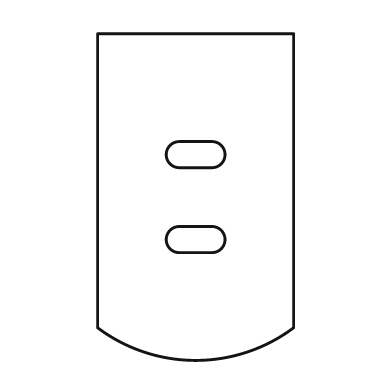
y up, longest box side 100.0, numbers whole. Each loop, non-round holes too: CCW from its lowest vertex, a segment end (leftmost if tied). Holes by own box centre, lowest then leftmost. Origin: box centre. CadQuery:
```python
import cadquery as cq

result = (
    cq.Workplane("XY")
    .moveTo(-30.0, -40.0)
    .threePointArc((0.0, -50.0), (30.0, -40.0))
    .lineTo(30.0, 50.0)
    .lineTo(-30.0, 50.0)
    .close()
    .moveTo(-5.0, -17.0)
    .lineTo(5.0, -17.0)
    .threePointArc((9.0, -13.0), (5.0, -9.0))
    .lineTo(-5.0, -9.0)
    .threePointArc((-9.0, -13.0), (-5.0, -17.0))
    .close()
    .moveTo(-5.0, 9.0)
    .lineTo(5.0, 9.0)
    .threePointArc((9.0, 13.0), (5.0, 17.0))
    .lineTo(-5.0, 17.0)
    .threePointArc((-9.0, 13.0), (-5.0, 9.0))
    .close()
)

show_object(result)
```